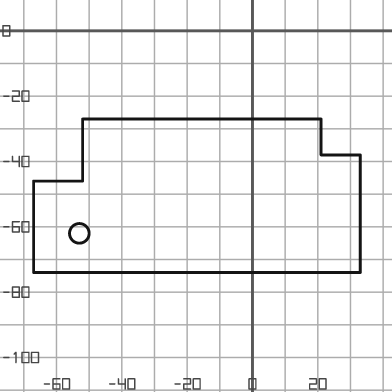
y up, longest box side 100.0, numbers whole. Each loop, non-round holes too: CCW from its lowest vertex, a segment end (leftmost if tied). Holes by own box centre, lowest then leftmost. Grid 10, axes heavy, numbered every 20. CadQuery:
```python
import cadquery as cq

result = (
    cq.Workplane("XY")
    .moveTo(-67.0, -74.0)
    .lineTo(33.0, -74.0)
    .lineTo(33.0, -38.0)
    .lineTo(21.0, -38.0)
    .lineTo(21.0, -27.0)
    .lineTo(-52.0, -27.0)
    .lineTo(-52.0, -46.0)
    .lineTo(-67.0, -46.0)
    .close()
    .moveTo(-53.0, -62.0)
    .circle(3.0)
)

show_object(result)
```